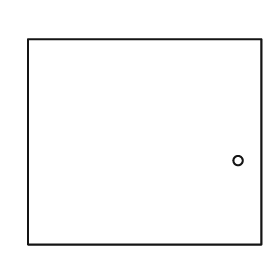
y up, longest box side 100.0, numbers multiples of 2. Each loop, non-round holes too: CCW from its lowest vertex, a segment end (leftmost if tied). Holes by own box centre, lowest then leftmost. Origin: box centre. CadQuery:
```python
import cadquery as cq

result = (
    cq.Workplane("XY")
    .moveTo(-50.0, -44.0)
    .lineTo(50.0, -44.0)
    .lineTo(50.0, 44.0)
    .lineTo(-50.0, 44.0)
    .close()
    .moveTo(40.0, -8.0)
    .circle(2.0)
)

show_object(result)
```